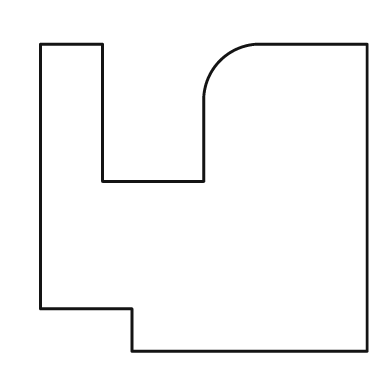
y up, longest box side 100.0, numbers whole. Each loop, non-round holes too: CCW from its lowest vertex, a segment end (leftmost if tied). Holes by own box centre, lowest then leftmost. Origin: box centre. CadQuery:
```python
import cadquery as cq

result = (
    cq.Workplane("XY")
    .moveTo(-22.0, -47.0)
    .lineTo(50.0, -47.0)
    .lineTo(50.0, 47.0)
    .lineTo(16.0, 47.0)
    .threePointArc((5.0, 42.0), (0.0, 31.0))
    .lineTo(0.0, 5.0)
    .lineTo(-31.0, 5.0)
    .lineTo(-31.0, 47.0)
    .lineTo(-50.0, 47.0)
    .lineTo(-50.0, -34.0)
    .lineTo(-22.0, -34.0)
    .close()
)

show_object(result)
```